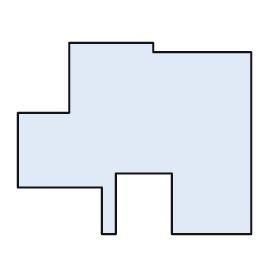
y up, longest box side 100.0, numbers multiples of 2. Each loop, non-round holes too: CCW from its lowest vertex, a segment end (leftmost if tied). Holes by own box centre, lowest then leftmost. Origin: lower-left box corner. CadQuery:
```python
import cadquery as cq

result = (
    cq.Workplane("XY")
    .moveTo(36.0, 0.0)
    .lineTo(42.0, 0.0)
    .lineTo(42.0, 26.0)
    .lineTo(66.0, 26.0)
    .lineTo(66.0, 0.0)
    .lineTo(100.0, 0.0)
    .lineTo(100.0, 78.0)
    .lineTo(58.0, 78.0)
    .lineTo(58.0, 82.0)
    .lineTo(22.0, 82.0)
    .lineTo(22.0, 52.0)
    .lineTo(0.0, 52.0)
    .lineTo(0.0, 20.0)
    .lineTo(36.0, 20.0)
    .close()
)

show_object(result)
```